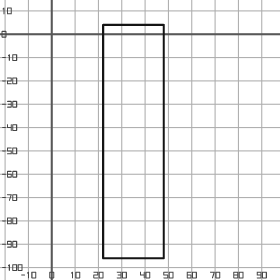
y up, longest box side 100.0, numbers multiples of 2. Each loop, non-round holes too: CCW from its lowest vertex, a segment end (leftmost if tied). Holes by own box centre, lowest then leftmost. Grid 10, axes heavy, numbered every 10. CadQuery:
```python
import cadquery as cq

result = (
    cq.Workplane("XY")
    .moveTo(22.0, -96.0)
    .lineTo(48.0, -96.0)
    .lineTo(48.0, 4.0)
    .lineTo(22.0, 4.0)
    .close()
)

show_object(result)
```